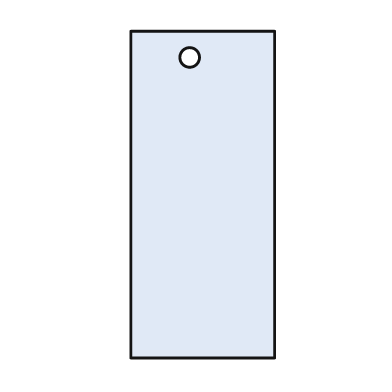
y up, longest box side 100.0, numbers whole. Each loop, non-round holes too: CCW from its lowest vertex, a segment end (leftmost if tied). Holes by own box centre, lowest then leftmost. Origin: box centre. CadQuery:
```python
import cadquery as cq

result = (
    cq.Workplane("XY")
    .moveTo(-22.0, -50.0)
    .lineTo(22.0, -50.0)
    .lineTo(22.0, 50.0)
    .lineTo(-22.0, 50.0)
    .close()
    .moveTo(-4.0, 42.0)
    .circle(3.0)
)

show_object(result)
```